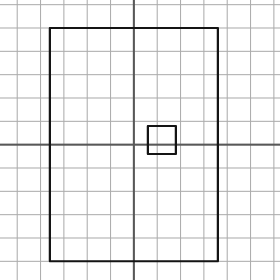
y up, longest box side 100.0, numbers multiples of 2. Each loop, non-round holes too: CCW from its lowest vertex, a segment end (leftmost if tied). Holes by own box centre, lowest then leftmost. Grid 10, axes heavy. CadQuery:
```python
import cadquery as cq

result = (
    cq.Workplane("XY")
    .moveTo(-36.0, -50.0)
    .lineTo(36.0, -50.0)
    .lineTo(36.0, 50.0)
    .lineTo(-36.0, 50.0)
    .close()
    .moveTo(6.0, -4.0)
    .lineTo(18.0, -4.0)
    .lineTo(18.0, 8.0)
    .lineTo(6.0, 8.0)
    .close()
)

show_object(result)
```